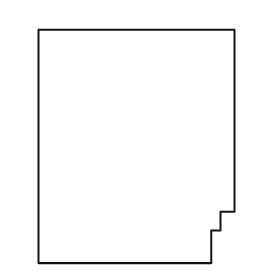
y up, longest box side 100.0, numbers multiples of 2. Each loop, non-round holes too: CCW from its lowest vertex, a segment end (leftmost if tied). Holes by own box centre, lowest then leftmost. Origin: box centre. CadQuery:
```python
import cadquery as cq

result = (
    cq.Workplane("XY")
    .moveTo(-42.0, -50.0)
    .lineTo(32.0, -50.0)
    .lineTo(32.0, -36.0)
    .lineTo(36.0, -36.0)
    .lineTo(36.0, -28.0)
    .lineTo(42.0, -28.0)
    .lineTo(42.0, 50.0)
    .lineTo(-42.0, 50.0)
    .close()
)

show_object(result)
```